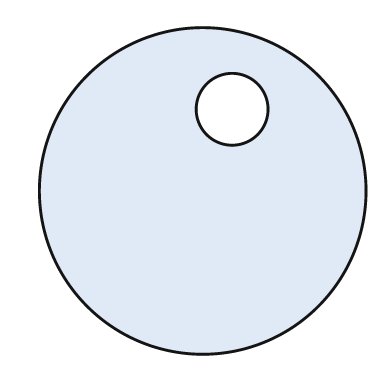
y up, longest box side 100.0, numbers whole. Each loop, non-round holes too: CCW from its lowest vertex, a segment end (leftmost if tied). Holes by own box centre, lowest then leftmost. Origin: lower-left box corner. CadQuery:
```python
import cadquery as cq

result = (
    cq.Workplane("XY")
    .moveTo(50.0, 50.0)
    .circle(50.0)
    .moveTo(59.0, 75.0)
    .circle(11.0)
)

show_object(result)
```